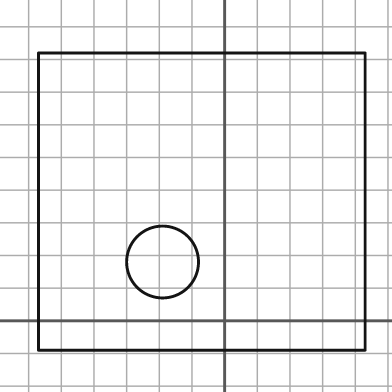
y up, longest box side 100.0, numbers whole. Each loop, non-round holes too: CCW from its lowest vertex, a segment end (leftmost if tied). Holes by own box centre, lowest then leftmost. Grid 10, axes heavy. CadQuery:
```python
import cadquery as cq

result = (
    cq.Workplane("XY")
    .moveTo(-57.0, -9.0)
    .lineTo(43.0, -9.0)
    .lineTo(43.0, 82.0)
    .lineTo(-57.0, 82.0)
    .close()
    .moveTo(-19.0, 18.0)
    .circle(11.0)
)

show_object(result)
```